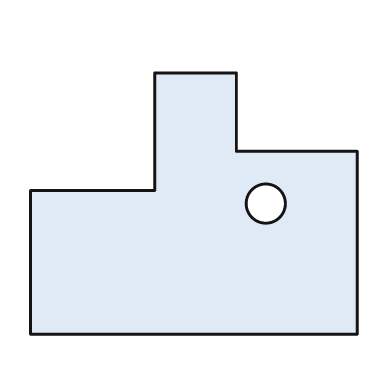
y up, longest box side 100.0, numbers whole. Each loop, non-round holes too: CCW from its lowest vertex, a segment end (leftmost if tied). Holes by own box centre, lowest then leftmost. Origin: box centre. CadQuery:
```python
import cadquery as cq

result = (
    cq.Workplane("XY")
    .moveTo(-50.0, -40.0)
    .lineTo(50.0, -40.0)
    .lineTo(50.0, 16.0)
    .lineTo(13.0, 16.0)
    .lineTo(13.0, 40.0)
    .lineTo(-12.0, 40.0)
    .lineTo(-12.0, 4.0)
    .lineTo(-50.0, 4.0)
    .close()
    .moveTo(22.0, 0.0)
    .circle(6.0)
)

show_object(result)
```